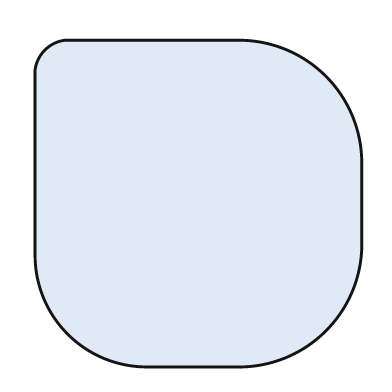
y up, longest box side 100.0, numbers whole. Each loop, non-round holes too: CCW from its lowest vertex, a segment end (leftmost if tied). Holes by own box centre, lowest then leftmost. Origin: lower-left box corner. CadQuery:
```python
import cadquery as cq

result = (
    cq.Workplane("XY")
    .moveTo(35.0, 0.0)
    .lineTo(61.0, 0.0)
    .threePointArc((89.0, 11.0), (100.0, 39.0))
    .lineTo(100.0, 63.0)
    .threePointArc((89.0, 89.0), (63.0, 100.0))
    .lineTo(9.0, 100.0)
    .threePointArc((3.0, 97.0), (0.0, 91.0))
    .lineTo(0.0, 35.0)
    .threePointArc((10.0, 10.0), (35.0, 0.0))
    .close()
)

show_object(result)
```